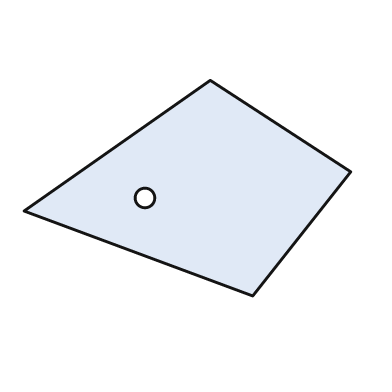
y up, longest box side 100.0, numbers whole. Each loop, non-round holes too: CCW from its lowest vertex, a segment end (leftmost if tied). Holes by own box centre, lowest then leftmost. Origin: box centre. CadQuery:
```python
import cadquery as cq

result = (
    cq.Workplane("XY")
    .moveTo(20.0, -33.0)
    .lineTo(50.0, 5.0)
    .lineTo(7.0, 33.0)
    .lineTo(-50.0, -7.0)
    .close()
    .moveTo(-13.0, -3.0)
    .circle(3.0)
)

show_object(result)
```